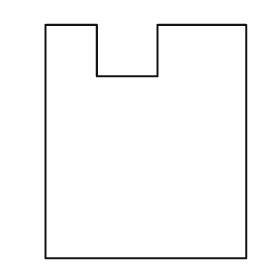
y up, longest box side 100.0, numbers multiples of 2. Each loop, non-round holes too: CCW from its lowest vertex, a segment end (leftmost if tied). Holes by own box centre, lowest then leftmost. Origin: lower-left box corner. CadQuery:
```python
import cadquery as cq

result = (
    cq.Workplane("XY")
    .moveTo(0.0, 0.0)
    .lineTo(86.0, 0.0)
    .lineTo(86.0, 100.0)
    .lineTo(48.0, 100.0)
    .lineTo(48.0, 78.0)
    .lineTo(22.0, 78.0)
    .lineTo(22.0, 100.0)
    .lineTo(0.0, 100.0)
    .close()
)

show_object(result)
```